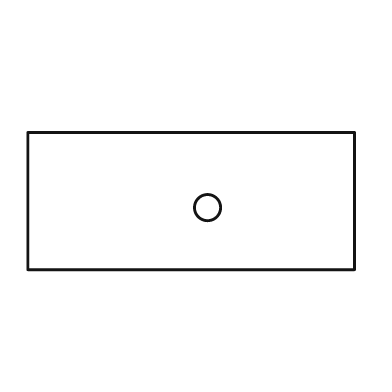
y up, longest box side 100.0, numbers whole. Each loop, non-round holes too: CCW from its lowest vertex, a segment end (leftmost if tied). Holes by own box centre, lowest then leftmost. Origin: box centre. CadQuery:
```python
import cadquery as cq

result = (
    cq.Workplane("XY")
    .moveTo(-50.0, -21.0)
    .lineTo(50.0, -21.0)
    .lineTo(50.0, 21.0)
    .lineTo(-50.0, 21.0)
    .close()
    .moveTo(5.0, -2.0)
    .circle(4.0)
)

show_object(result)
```